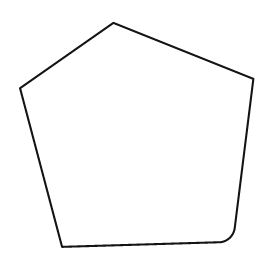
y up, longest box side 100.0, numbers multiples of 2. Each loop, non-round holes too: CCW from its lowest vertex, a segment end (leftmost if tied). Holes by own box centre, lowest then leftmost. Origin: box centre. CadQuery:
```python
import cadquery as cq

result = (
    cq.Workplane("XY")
    .moveTo(-32.0, -48.0)
    .lineTo(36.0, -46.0)
    .threePointArc((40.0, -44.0), (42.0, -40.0))
    .lineTo(50.0, 24.0)
    .lineTo(-10.0, 48.0)
    .lineTo(-50.0, 20.0)
    .close()
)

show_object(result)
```